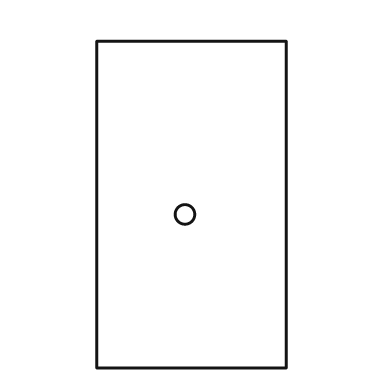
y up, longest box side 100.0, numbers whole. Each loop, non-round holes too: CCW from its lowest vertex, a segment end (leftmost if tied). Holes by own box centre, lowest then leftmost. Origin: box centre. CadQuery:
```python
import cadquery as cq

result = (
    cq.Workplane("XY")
    .moveTo(-29.0, -50.0)
    .lineTo(29.0, -50.0)
    .lineTo(29.0, 50.0)
    .lineTo(-29.0, 50.0)
    .close()
    .moveTo(-2.0, -3.0)
    .circle(3.0)
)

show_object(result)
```